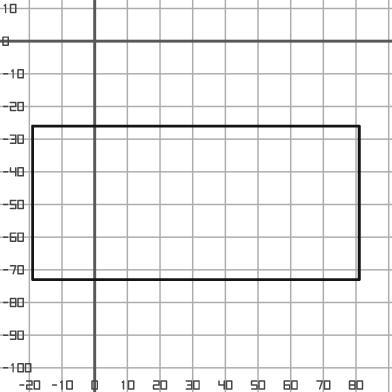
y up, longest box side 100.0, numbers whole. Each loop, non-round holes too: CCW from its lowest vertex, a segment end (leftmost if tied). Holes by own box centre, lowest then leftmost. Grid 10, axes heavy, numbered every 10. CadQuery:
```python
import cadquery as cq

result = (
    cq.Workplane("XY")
    .moveTo(-19.0, -73.0)
    .lineTo(81.0, -73.0)
    .lineTo(81.0, -26.0)
    .lineTo(-19.0, -26.0)
    .close()
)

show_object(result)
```